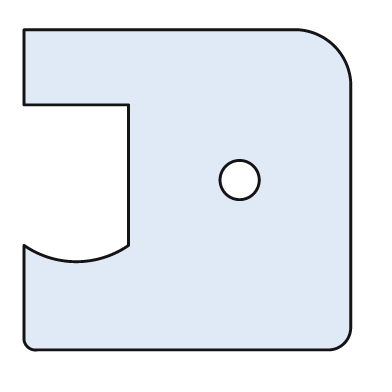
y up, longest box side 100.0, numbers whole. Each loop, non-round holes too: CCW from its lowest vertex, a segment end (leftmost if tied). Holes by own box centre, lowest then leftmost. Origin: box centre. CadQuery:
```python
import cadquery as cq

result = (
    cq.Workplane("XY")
    .moveTo(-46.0, -49.0)
    .lineTo(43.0, -49.0)
    .threePointArc((48.0, -47.0), (50.0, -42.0))
    .lineTo(50.0, 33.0)
    .threePointArc((45.0, 44.0), (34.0, 49.0))
    .lineTo(-50.0, 49.0)
    .lineTo(-50.0, 26.0)
    .lineTo(-18.0, 26.0)
    .lineTo(-18.0, -17.0)
    .threePointArc((-34.0, -22.0), (-50.0, -17.0))
    .lineTo(-50.0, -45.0)
    .threePointArc((-49.0, -48.0), (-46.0, -49.0))
    .close()
    .moveTo(16.0, 3.0)
    .circle(6.0)
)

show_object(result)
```